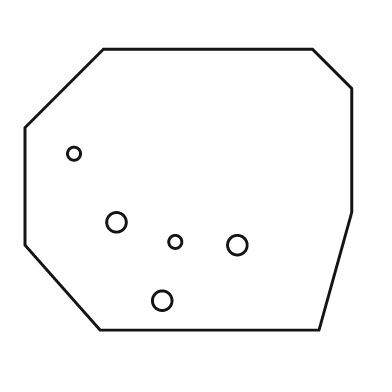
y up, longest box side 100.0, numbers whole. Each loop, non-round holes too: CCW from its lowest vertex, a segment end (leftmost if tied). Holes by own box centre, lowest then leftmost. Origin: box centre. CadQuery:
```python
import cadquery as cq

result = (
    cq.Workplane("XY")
    .moveTo(-27.0, -43.0)
    .lineTo(40.0, -43.0)
    .lineTo(50.0, -7.0)
    .lineTo(50.0, 31.0)
    .lineTo(38.0, 43.0)
    .lineTo(-26.0, 43.0)
    .lineTo(-50.0, 19.0)
    .lineTo(-50.0, -17.0)
    .close()
    .moveTo(-8.0, -34.0)
    .circle(3.0)
    .moveTo(15.0, -17.0)
    .circle(3.0)
    .moveTo(-4.0, -16.0)
    .circle(2.0)
    .moveTo(-22.0, -10.0)
    .circle(3.0)
    .moveTo(-35.0, 11.0)
    .circle(2.0)
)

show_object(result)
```